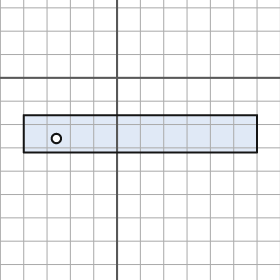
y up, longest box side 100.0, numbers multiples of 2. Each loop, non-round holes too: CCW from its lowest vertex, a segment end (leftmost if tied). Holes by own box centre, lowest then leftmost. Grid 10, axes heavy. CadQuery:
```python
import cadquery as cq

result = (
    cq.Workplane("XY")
    .moveTo(-40.0, -32.0)
    .lineTo(60.0, -32.0)
    .lineTo(60.0, -16.0)
    .lineTo(-40.0, -16.0)
    .close()
    .moveTo(-26.0, -26.0)
    .circle(2.0)
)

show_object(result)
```